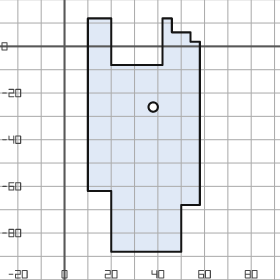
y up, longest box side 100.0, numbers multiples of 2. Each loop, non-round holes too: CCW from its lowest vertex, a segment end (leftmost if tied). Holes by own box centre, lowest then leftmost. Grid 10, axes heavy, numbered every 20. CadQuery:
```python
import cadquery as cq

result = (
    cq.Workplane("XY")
    .moveTo(20.0, -88.0)
    .lineTo(50.0, -88.0)
    .lineTo(50.0, -68.0)
    .lineTo(58.0, -68.0)
    .lineTo(58.0, 2.0)
    .lineTo(54.0, 2.0)
    .lineTo(54.0, 6.0)
    .lineTo(46.0, 6.0)
    .lineTo(46.0, 12.0)
    .lineTo(42.0, 12.0)
    .lineTo(42.0, -8.0)
    .lineTo(20.0, -8.0)
    .lineTo(20.0, 12.0)
    .lineTo(10.0, 12.0)
    .lineTo(10.0, -62.0)
    .lineTo(20.0, -62.0)
    .close()
    .moveTo(38.0, -26.0)
    .circle(2.0)
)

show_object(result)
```